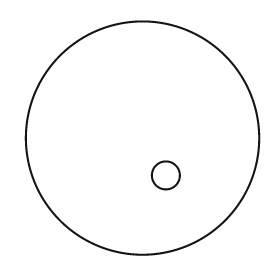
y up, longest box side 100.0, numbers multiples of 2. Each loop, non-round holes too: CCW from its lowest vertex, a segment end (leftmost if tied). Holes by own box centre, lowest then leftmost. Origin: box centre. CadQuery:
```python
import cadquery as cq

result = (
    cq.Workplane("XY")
    .moveTo(0.0, 0.0)
    .circle(50.0)
    .moveTo(10.0, -16.0)
    .circle(6.0)
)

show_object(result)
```